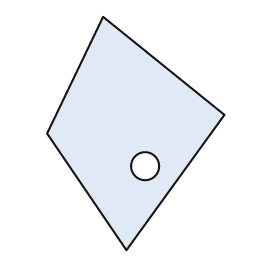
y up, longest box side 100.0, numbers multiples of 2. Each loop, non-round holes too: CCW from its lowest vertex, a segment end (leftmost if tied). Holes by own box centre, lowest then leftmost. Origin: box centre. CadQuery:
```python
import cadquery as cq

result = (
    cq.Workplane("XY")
    .moveTo(-4.0, -50.0)
    .lineTo(38.0, 8.0)
    .lineTo(-14.0, 50.0)
    .lineTo(-38.0, 0.0)
    .close()
    .moveTo(4.0, -14.0)
    .circle(6.0)
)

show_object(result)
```